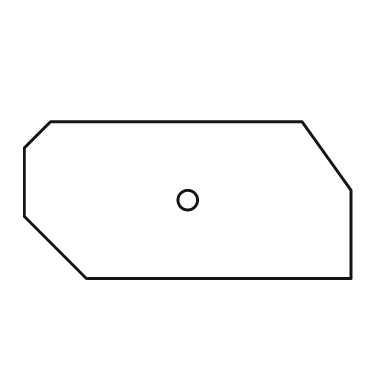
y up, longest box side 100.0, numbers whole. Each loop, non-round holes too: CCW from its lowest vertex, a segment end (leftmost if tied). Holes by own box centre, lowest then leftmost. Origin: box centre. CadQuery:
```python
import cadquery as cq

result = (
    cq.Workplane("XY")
    .moveTo(-31.0, -24.0)
    .lineTo(50.0, -24.0)
    .lineTo(50.0, 3.0)
    .lineTo(35.0, 24.0)
    .lineTo(-42.0, 24.0)
    .lineTo(-50.0, 16.0)
    .lineTo(-50.0, -5.0)
    .close()
    .moveTo(0.0, 0.0)
    .circle(3.0)
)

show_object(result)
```